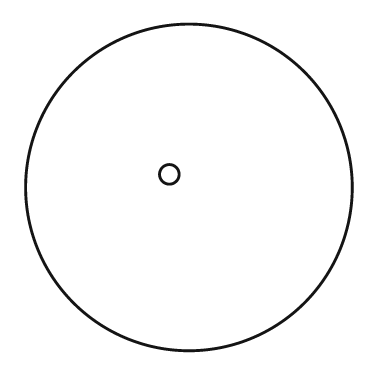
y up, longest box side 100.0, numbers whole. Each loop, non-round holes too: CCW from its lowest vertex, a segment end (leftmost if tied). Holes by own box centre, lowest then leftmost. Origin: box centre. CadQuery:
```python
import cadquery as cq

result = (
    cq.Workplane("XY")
    .moveTo(0.0, 0.0)
    .circle(50.0)
    .moveTo(-6.0, 4.0)
    .circle(3.0)
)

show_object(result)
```